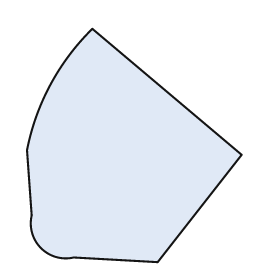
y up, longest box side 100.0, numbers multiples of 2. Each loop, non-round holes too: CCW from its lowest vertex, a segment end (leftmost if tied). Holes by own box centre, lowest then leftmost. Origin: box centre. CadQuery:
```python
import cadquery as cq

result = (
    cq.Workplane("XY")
    .moveTo(10.0, -50.0)
    .lineTo(46.0, -4.0)
    .lineTo(-18.0, 50.0)
    .threePointArc((-36.0, 26.0), (-46.0, -2.0))
    .lineTo(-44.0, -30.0)
    .threePointArc((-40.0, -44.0), (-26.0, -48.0))
    .close()
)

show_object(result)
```